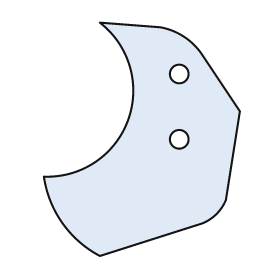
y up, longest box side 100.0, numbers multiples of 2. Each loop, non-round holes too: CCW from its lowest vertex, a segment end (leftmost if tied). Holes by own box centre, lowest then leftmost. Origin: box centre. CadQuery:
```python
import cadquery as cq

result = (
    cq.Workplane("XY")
    .moveTo(-18.0, -50.0)
    .lineTo(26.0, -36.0)
    .threePointArc((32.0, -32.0), (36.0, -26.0))
    .lineTo(42.0, 12.0)
    .lineTo(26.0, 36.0)
    .threePointArc((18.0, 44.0), (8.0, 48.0))
    .lineTo(-18.0, 50.0)
    .threePointArc((-6.0, 8.0), (-42.0, -16.0))
    .threePointArc((-34.0, -36.0), (-18.0, -50.0))
    .close()
    .moveTo(16.0, 0.0)
    .circle(4.0)
    .moveTo(16.0, 28.0)
    .circle(4.0)
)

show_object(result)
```